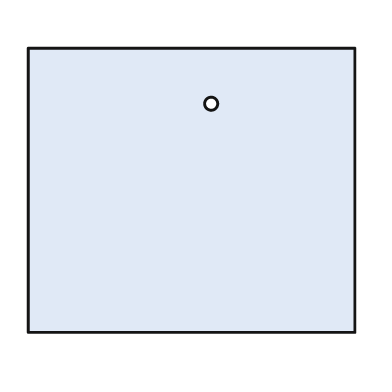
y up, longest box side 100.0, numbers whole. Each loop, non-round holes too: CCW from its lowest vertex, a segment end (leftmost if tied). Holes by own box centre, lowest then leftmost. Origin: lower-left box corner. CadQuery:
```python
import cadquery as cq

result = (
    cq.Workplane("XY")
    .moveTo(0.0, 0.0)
    .lineTo(100.0, 0.0)
    .lineTo(100.0, 87.0)
    .lineTo(0.0, 87.0)
    .close()
    .moveTo(56.0, 70.0)
    .circle(2.0)
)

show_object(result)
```